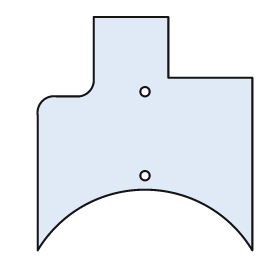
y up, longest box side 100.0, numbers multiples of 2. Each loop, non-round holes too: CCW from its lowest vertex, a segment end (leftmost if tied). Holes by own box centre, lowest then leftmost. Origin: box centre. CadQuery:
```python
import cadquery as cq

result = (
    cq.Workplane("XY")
    .moveTo(-46.0, -50.0)
    .threePointArc((0.0, -24.0), (46.0, -50.0))
    .lineTo(46.0, 24.0)
    .lineTo(10.0, 24.0)
    .lineTo(10.0, 50.0)
    .lineTo(-22.0, 50.0)
    .lineTo(-22.0, 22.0)
    .threePointArc((-24.0, 18.0), (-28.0, 16.0))
    .lineTo(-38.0, 16.0)
    .threePointArc((-44.0, 14.0), (-46.0, 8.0))
    .close()
    .moveTo(0.0, -18.0)
    .circle(2.0)
    .moveTo(0.0, 18.0)
    .circle(2.0)
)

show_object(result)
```